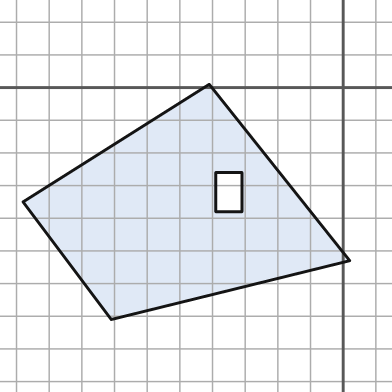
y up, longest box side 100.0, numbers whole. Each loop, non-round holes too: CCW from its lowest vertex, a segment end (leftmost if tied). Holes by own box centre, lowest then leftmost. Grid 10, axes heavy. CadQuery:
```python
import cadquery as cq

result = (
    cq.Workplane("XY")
    .moveTo(-71.0, -71.0)
    .lineTo(2.0, -53.0)
    .lineTo(-41.0, 1.0)
    .lineTo(-98.0, -35.0)
    .close()
    .moveTo(-39.0, -38.0)
    .lineTo(-31.0, -38.0)
    .lineTo(-31.0, -26.0)
    .lineTo(-39.0, -26.0)
    .close()
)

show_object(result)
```